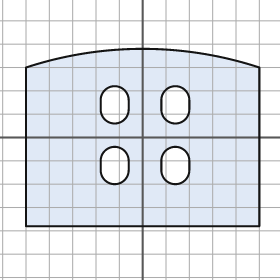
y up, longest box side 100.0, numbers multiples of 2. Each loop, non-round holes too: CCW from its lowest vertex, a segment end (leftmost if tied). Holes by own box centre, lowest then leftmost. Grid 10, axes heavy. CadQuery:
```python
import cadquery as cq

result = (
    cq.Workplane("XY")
    .moveTo(-50.0, -38.0)
    .lineTo(50.0, -38.0)
    .lineTo(50.0, 30.0)
    .threePointArc((0.0, 38.0), (-50.0, 30.0))
    .close()
    .moveTo(-18.0, -14.0)
    .threePointArc((-12.0, -20.0), (-6.0, -14.0))
    .lineTo(-6.0, -10.0)
    .threePointArc((-12.0, -4.0), (-18.0, -10.0))
    .close()
    .moveTo(8.0, -14.0)
    .threePointArc((14.0, -20.0), (20.0, -14.0))
    .lineTo(20.0, -10.0)
    .threePointArc((14.0, -4.0), (8.0, -10.0))
    .close()
    .moveTo(-18.0, 12.0)
    .threePointArc((-12.0, 6.0), (-6.0, 12.0))
    .lineTo(-6.0, 16.0)
    .threePointArc((-12.0, 22.0), (-18.0, 16.0))
    .close()
    .moveTo(8.0, 12.0)
    .threePointArc((14.0, 6.0), (20.0, 12.0))
    .lineTo(20.0, 16.0)
    .threePointArc((14.0, 22.0), (8.0, 16.0))
    .close()
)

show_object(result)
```